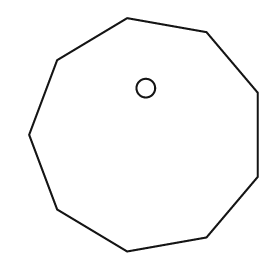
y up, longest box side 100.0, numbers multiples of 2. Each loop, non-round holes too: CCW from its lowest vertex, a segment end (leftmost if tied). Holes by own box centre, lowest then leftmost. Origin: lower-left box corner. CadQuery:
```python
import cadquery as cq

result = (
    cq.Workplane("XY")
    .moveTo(42.0, 0.0)
    .lineTo(76.0, 6.0)
    .lineTo(98.0, 32.0)
    .lineTo(98.0, 68.0)
    .lineTo(76.0, 94.0)
    .lineTo(42.0, 100.0)
    .lineTo(12.0, 82.0)
    .lineTo(0.0, 50.0)
    .lineTo(12.0, 18.0)
    .close()
    .moveTo(50.0, 70.0)
    .circle(4.0)
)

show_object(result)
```